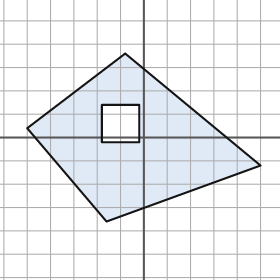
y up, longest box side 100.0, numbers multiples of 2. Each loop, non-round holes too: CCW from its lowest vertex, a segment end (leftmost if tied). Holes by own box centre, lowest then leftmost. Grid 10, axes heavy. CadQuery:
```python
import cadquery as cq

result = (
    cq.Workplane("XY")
    .moveTo(-16.0, -36.0)
    .lineTo(50.0, -12.0)
    .lineTo(-8.0, 36.0)
    .lineTo(-50.0, 4.0)
    .close()
    .moveTo(-18.0, -2.0)
    .lineTo(-2.0, -2.0)
    .lineTo(-2.0, 14.0)
    .lineTo(-18.0, 14.0)
    .close()
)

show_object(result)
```